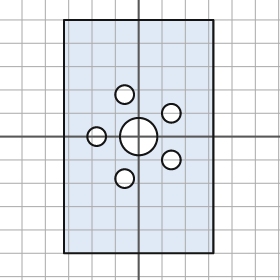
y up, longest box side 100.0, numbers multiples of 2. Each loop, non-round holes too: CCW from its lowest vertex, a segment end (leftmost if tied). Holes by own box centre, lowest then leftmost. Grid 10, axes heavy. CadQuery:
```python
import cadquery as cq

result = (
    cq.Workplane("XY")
    .moveTo(-32.0, -50.0)
    .lineTo(32.0, -50.0)
    .lineTo(32.0, 50.0)
    .lineTo(-32.0, 50.0)
    .close()
    .moveTo(-6.0, -18.0)
    .circle(4.0)
    .moveTo(14.0, -10.0)
    .circle(4.0)
    .moveTo(-18.0, 0.0)
    .circle(4.0)
    .moveTo(0.0, 0.0)
    .circle(8.0)
    .moveTo(14.0, 10.0)
    .circle(4.0)
    .moveTo(-6.0, 18.0)
    .circle(4.0)
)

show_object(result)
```